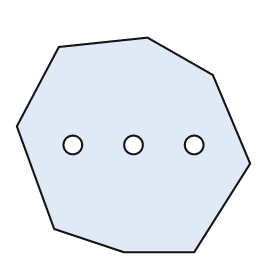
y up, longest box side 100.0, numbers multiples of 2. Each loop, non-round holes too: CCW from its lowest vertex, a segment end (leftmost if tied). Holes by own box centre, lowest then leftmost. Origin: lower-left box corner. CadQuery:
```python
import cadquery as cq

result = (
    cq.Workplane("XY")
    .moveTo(46.0, 0.0)
    .lineTo(76.0, 0.0)
    .lineTo(100.0, 38.0)
    .lineTo(84.0, 76.0)
    .lineTo(56.0, 92.0)
    .lineTo(18.0, 88.0)
    .lineTo(0.0, 54.0)
    .lineTo(16.0, 10.0)
    .close()
    .moveTo(24.0, 46.0)
    .circle(4.0)
    .moveTo(50.0, 46.0)
    .circle(4.0)
    .moveTo(76.0, 46.0)
    .circle(4.0)
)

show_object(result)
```